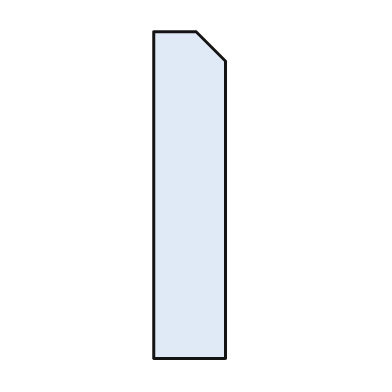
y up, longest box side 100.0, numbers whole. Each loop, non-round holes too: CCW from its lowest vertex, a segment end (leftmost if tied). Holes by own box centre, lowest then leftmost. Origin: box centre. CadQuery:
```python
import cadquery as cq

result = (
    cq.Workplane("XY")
    .moveTo(-11.0, -50.0)
    .lineTo(11.0, -50.0)
    .lineTo(11.0, 41.0)
    .lineTo(2.0, 50.0)
    .lineTo(-11.0, 50.0)
    .close()
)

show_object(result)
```